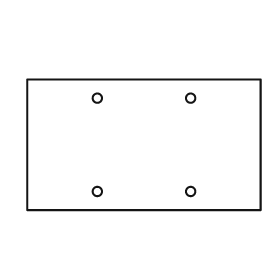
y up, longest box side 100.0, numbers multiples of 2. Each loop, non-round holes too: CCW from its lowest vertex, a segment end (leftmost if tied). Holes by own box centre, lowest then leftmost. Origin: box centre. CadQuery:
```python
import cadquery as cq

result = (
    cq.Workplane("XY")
    .moveTo(-50.0, -28.0)
    .lineTo(50.0, -28.0)
    .lineTo(50.0, 28.0)
    .lineTo(-50.0, 28.0)
    .close()
    .moveTo(-20.0, -20.0)
    .circle(2.0)
    .moveTo(20.0, -20.0)
    .circle(2.0)
    .moveTo(-20.0, 20.0)
    .circle(2.0)
    .moveTo(20.0, 20.0)
    .circle(2.0)
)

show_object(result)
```